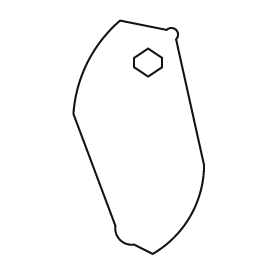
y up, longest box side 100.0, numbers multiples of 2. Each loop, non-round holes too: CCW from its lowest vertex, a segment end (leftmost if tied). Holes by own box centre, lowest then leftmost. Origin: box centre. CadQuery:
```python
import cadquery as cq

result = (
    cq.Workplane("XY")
    .moveTo(6.0, -50.0)
    .threePointArc((22.0, -34.0), (28.0, -12.0))
    .lineTo(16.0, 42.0)
    .threePointArc((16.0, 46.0), (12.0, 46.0))
    .lineTo(-8.0, 50.0)
    .threePointArc((-22.0, 32.0), (-28.0, 10.0))
    .lineTo(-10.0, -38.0)
    .threePointArc((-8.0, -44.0), (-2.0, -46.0))
    .close()
    .moveTo(4.0, 26.0)
    .lineTo(10.0, 30.0)
    .lineTo(10.0, 34.0)
    .lineTo(4.0, 38.0)
    .lineTo(-2.0, 34.0)
    .lineTo(-2.0, 30.0)
    .close()
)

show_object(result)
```